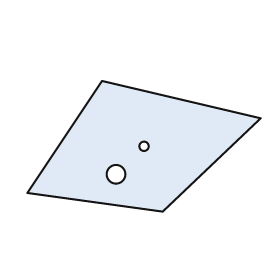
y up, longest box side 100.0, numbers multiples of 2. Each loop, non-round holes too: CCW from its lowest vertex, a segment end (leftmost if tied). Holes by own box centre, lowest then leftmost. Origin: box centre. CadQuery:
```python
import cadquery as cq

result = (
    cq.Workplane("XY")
    .moveTo(8.0, -28.0)
    .lineTo(50.0, 12.0)
    .lineTo(-18.0, 28.0)
    .lineTo(-50.0, -20.0)
    .close()
    .moveTo(-12.0, -12.0)
    .circle(4.0)
    .moveTo(0.0, 0.0)
    .circle(2.0)
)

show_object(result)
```